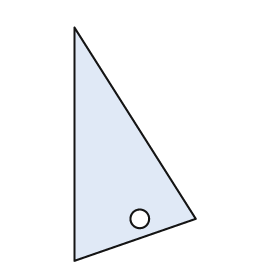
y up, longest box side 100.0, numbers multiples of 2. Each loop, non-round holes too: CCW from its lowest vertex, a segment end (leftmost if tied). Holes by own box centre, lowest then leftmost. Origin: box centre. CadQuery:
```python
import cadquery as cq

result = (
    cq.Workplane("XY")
    .moveTo(-26.0, -50.0)
    .lineTo(26.0, -32.0)
    .lineTo(-26.0, 50.0)
    .close()
    .moveTo(2.0, -32.0)
    .circle(4.0)
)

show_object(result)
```